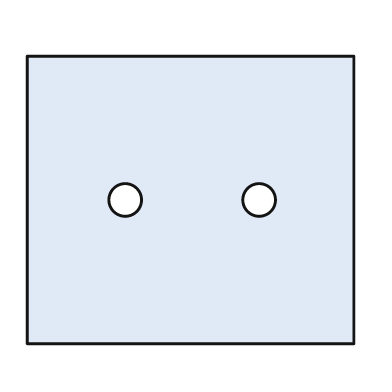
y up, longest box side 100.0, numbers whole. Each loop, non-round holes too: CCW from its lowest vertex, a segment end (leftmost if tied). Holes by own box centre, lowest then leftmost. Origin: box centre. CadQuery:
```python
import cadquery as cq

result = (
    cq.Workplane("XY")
    .moveTo(-50.0, -44.0)
    .lineTo(50.0, -44.0)
    .lineTo(50.0, 44.0)
    .lineTo(-50.0, 44.0)
    .close()
    .moveTo(-20.0, 0.0)
    .circle(5.0)
    .moveTo(21.0, 0.0)
    .circle(5.0)
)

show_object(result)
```